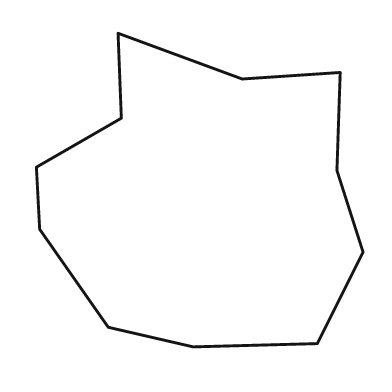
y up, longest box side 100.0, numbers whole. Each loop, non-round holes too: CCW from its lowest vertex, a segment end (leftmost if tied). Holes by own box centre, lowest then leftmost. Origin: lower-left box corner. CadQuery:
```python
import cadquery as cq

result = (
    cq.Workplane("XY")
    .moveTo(48.0, 0.0)
    .lineTo(86.0, 1.0)
    .lineTo(100.0, 29.0)
    .lineTo(92.0, 54.0)
    .lineTo(93.0, 84.0)
    .lineTo(63.0, 82.0)
    .lineTo(25.0, 96.0)
    .lineTo(26.0, 70.0)
    .lineTo(0.0, 55.0)
    .lineTo(1.0, 36.0)
    .lineTo(22.0, 6.0)
    .close()
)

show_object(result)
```